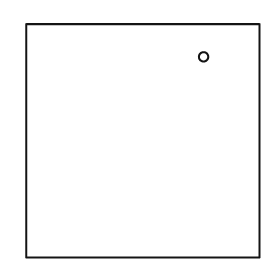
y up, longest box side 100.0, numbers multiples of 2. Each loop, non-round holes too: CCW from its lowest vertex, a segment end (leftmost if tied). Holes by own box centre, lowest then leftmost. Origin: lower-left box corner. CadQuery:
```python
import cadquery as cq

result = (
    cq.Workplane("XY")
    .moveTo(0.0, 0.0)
    .lineTo(100.0, 0.0)
    .lineTo(100.0, 100.0)
    .lineTo(0.0, 100.0)
    .close()
    .moveTo(76.0, 86.0)
    .circle(2.0)
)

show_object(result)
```